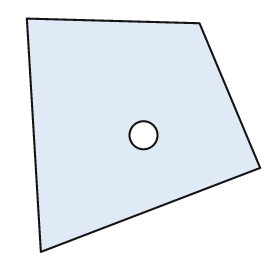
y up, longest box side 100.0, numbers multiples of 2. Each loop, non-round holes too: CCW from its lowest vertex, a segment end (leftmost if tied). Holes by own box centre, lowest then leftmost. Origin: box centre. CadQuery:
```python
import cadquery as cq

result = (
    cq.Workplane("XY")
    .moveTo(-44.0, -50.0)
    .lineTo(50.0, -14.0)
    .lineTo(24.0, 48.0)
    .lineTo(-50.0, 50.0)
    .close()
    .moveTo(0.0, 0.0)
    .circle(6.0)
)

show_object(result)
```